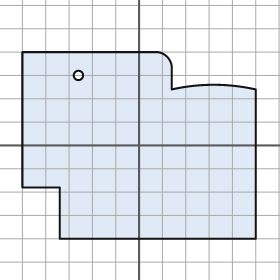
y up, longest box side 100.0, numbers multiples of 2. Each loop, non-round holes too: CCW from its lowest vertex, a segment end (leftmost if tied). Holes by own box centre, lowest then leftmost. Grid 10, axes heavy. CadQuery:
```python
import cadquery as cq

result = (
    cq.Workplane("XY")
    .moveTo(-34.0, -40.0)
    .lineTo(50.0, -40.0)
    .lineTo(50.0, 24.0)
    .threePointArc((32.0, 26.0), (14.0, 24.0))
    .lineTo(14.0, 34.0)
    .threePointArc((12.0, 38.0), (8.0, 40.0))
    .lineTo(-50.0, 40.0)
    .lineTo(-50.0, -18.0)
    .lineTo(-34.0, -18.0)
    .close()
    .moveTo(-26.0, 30.0)
    .circle(2.0)
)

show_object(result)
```